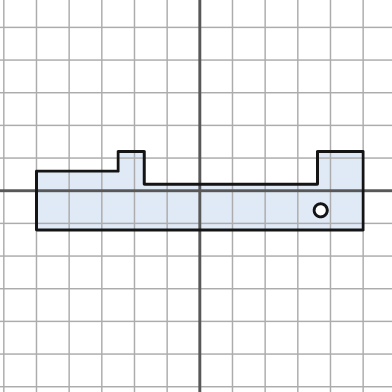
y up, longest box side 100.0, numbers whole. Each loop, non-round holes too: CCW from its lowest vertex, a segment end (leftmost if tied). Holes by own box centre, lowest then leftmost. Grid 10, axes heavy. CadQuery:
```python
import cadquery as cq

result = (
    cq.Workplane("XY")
    .moveTo(-50.0, -12.0)
    .lineTo(50.0, -12.0)
    .lineTo(50.0, 12.0)
    .lineTo(36.0, 12.0)
    .lineTo(36.0, 2.0)
    .lineTo(-17.0, 2.0)
    .lineTo(-17.0, 12.0)
    .lineTo(-25.0, 12.0)
    .lineTo(-25.0, 6.0)
    .lineTo(-50.0, 6.0)
    .close()
    .moveTo(37.0, -6.0)
    .circle(2.0)
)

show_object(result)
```